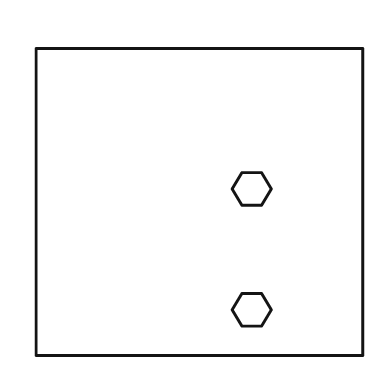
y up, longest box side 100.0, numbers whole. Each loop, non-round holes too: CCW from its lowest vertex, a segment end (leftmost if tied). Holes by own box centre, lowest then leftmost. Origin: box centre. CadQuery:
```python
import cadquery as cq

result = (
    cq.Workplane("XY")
    .moveTo(-50.0, -47.0)
    .lineTo(50.0, -47.0)
    .lineTo(50.0, 47.0)
    .lineTo(-50.0, 47.0)
    .close()
    .moveTo(13.0, -38.0)
    .lineTo(19.0, -38.0)
    .lineTo(22.0, -33.0)
    .lineTo(19.0, -28.0)
    .lineTo(13.0, -28.0)
    .lineTo(10.0, -33.0)
    .close()
    .moveTo(13.0, -1.0)
    .lineTo(19.0, -1.0)
    .lineTo(22.0, 4.0)
    .lineTo(19.0, 9.0)
    .lineTo(13.0, 9.0)
    .lineTo(10.0, 4.0)
    .close()
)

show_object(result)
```